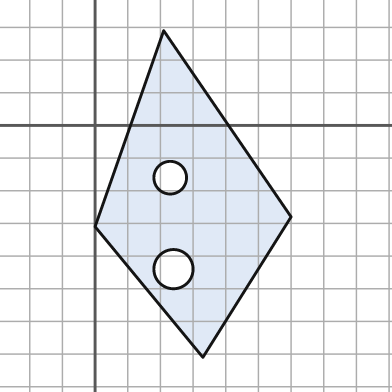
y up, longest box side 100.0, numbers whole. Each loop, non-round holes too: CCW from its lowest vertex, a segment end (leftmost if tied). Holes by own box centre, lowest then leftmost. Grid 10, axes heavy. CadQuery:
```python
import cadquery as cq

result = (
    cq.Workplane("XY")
    .moveTo(33.0, -71.0)
    .lineTo(60.0, -28.0)
    .lineTo(21.0, 29.0)
    .lineTo(0.0, -31.0)
    .close()
    .moveTo(24.0, -44.0)
    .circle(6.0)
    .moveTo(23.0, -16.0)
    .circle(5.0)
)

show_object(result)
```